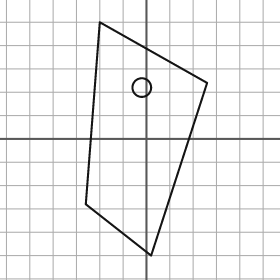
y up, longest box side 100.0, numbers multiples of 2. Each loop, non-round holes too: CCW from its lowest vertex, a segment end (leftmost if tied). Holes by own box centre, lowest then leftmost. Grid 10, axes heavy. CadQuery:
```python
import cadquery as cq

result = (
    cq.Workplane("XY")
    .moveTo(2.0, -50.0)
    .lineTo(26.0, 24.0)
    .lineTo(-20.0, 50.0)
    .lineTo(-26.0, -28.0)
    .close()
    .moveTo(-2.0, 22.0)
    .circle(4.0)
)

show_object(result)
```